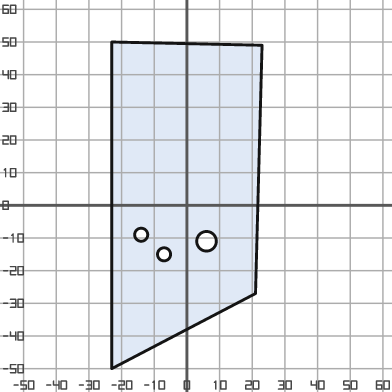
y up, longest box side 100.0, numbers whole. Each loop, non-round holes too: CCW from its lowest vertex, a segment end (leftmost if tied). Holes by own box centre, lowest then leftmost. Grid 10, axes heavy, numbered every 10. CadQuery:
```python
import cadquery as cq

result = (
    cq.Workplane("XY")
    .moveTo(-23.0, -50.0)
    .lineTo(21.0, -27.0)
    .lineTo(23.0, 49.0)
    .lineTo(-23.0, 50.0)
    .close()
    .moveTo(-7.0, -15.0)
    .circle(2.0)
    .moveTo(6.0, -11.0)
    .circle(3.0)
    .moveTo(-14.0, -9.0)
    .circle(2.0)
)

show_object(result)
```